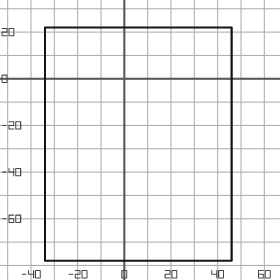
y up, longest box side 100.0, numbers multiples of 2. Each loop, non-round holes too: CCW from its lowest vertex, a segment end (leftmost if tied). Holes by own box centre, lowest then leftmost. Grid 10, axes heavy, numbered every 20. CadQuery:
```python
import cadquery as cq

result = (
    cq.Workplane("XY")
    .moveTo(-34.0, -78.0)
    .lineTo(46.0, -78.0)
    .lineTo(46.0, 22.0)
    .lineTo(-34.0, 22.0)
    .close()
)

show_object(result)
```